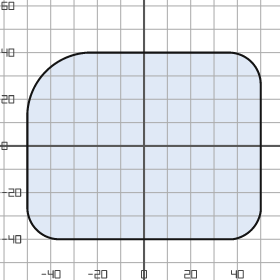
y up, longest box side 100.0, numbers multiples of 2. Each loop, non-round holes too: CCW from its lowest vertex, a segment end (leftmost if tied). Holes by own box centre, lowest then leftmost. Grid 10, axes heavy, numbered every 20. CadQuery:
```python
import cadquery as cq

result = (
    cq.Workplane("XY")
    .moveTo(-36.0, -40.0)
    .lineTo(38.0, -40.0)
    .threePointArc((46.0, -36.0), (50.0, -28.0))
    .lineTo(50.0, 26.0)
    .threePointArc((46.0, 36.0), (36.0, 40.0))
    .lineTo(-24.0, 40.0)
    .threePointArc((-42.0, 32.0), (-50.0, 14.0))
    .lineTo(-50.0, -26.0)
    .threePointArc((-46.0, -36.0), (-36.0, -40.0))
    .close()
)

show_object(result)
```